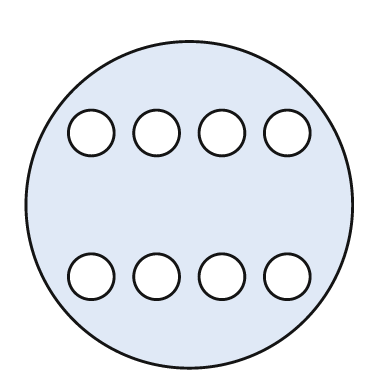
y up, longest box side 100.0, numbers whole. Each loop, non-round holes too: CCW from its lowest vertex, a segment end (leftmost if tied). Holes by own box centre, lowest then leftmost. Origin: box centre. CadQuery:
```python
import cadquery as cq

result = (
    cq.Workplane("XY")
    .moveTo(0.0, 0.0)
    .circle(50.0)
    .moveTo(-30.0, -22.0)
    .circle(7.0)
    .moveTo(-10.0, -22.0)
    .circle(7.0)
    .moveTo(10.0, -22.0)
    .circle(7.0)
    .moveTo(30.0, -22.0)
    .circle(7.0)
    .moveTo(-30.0, 22.0)
    .circle(7.0)
    .moveTo(-10.0, 22.0)
    .circle(7.0)
    .moveTo(10.0, 22.0)
    .circle(7.0)
    .moveTo(30.0, 22.0)
    .circle(7.0)
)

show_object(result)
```